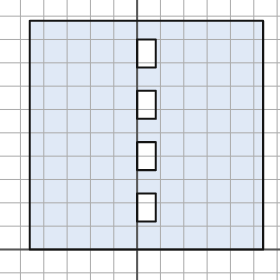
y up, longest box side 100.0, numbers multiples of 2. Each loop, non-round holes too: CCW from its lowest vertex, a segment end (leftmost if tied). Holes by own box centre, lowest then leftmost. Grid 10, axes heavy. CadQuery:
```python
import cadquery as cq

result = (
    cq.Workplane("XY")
    .moveTo(-46.0, 0.0)
    .lineTo(54.0, 0.0)
    .lineTo(54.0, 98.0)
    .lineTo(-46.0, 98.0)
    .close()
    .moveTo(0.0, 12.0)
    .lineTo(8.0, 12.0)
    .lineTo(8.0, 24.0)
    .lineTo(0.0, 24.0)
    .close()
    .moveTo(0.0, 34.0)
    .lineTo(8.0, 34.0)
    .lineTo(8.0, 46.0)
    .lineTo(0.0, 46.0)
    .close()
    .moveTo(0.0, 56.0)
    .lineTo(8.0, 56.0)
    .lineTo(8.0, 68.0)
    .lineTo(0.0, 68.0)
    .close()
    .moveTo(0.0, 78.0)
    .lineTo(8.0, 78.0)
    .lineTo(8.0, 90.0)
    .lineTo(0.0, 90.0)
    .close()
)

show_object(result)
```